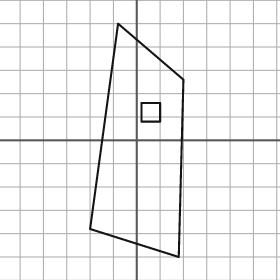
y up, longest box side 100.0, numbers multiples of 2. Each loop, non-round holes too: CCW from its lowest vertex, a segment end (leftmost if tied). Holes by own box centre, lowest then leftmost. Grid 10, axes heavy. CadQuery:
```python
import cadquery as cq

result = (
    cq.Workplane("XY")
    .moveTo(18.0, -50.0)
    .lineTo(20.0, 26.0)
    .lineTo(-8.0, 50.0)
    .lineTo(-20.0, -38.0)
    .close()
    .moveTo(2.0, 8.0)
    .lineTo(10.0, 8.0)
    .lineTo(10.0, 16.0)
    .lineTo(2.0, 16.0)
    .close()
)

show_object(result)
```